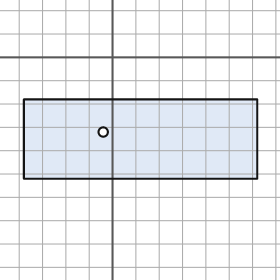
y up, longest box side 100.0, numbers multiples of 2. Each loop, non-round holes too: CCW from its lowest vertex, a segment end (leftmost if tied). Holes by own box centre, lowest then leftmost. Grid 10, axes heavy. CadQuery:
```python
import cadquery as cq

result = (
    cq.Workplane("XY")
    .moveTo(-38.0, -52.0)
    .lineTo(62.0, -52.0)
    .lineTo(62.0, -18.0)
    .lineTo(-38.0, -18.0)
    .close()
    .moveTo(-4.0, -32.0)
    .circle(2.0)
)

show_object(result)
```